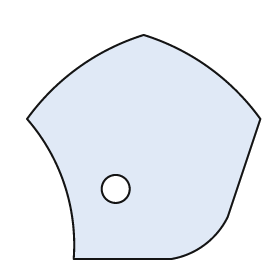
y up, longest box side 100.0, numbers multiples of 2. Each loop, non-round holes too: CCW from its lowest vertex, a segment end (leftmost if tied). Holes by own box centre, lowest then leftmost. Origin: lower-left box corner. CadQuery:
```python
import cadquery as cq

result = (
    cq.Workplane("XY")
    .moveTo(20.0, 0.0)
    .lineTo(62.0, 0.0)
    .threePointArc((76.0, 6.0), (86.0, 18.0))
    .lineTo(100.0, 60.0)
    .threePointArc((78.0, 82.0), (50.0, 96.0))
    .threePointArc((22.0, 82.0), (0.0, 60.0))
    .threePointArc((16.0, 32.0), (20.0, 0.0))
    .close()
    .moveTo(38.0, 30.0)
    .circle(6.0)
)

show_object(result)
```